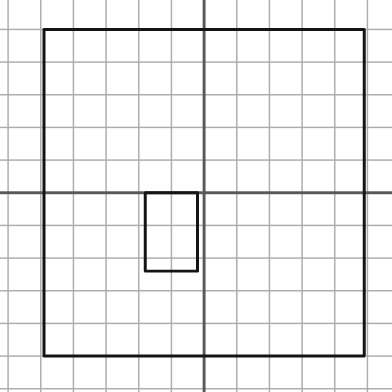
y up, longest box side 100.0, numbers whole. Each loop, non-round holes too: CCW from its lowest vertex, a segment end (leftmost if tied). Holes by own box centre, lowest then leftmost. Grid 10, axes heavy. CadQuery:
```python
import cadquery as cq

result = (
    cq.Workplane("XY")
    .moveTo(-49.0, -50.0)
    .lineTo(49.0, -50.0)
    .lineTo(49.0, 50.0)
    .lineTo(-49.0, 50.0)
    .close()
    .moveTo(-18.0, -24.0)
    .lineTo(-2.0, -24.0)
    .lineTo(-2.0, 0.0)
    .lineTo(-18.0, 0.0)
    .close()
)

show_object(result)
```